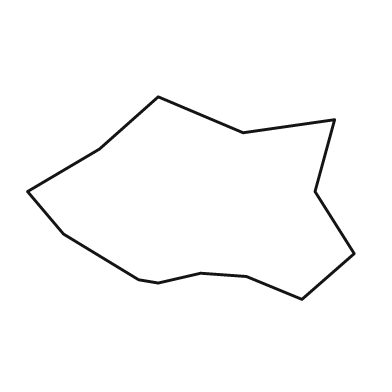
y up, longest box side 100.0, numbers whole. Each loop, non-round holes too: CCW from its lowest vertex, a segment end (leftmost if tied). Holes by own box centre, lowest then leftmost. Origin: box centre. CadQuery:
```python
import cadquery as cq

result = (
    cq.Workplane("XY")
    .moveTo(34.0, -31.0)
    .lineTo(50.0, -17.0)
    .lineTo(38.0, 2.0)
    .lineTo(44.0, 24.0)
    .lineTo(16.0, 20.0)
    .lineTo(-10.0, 31.0)
    .lineTo(-28.0, 15.0)
    .lineTo(-50.0, 2.0)
    .lineTo(-39.0, -11.0)
    .lineTo(-16.0, -25.0)
    .lineTo(-10.0, -26.0)
    .lineTo(3.0, -23.0)
    .lineTo(17.0, -24.0)
    .close()
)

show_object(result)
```